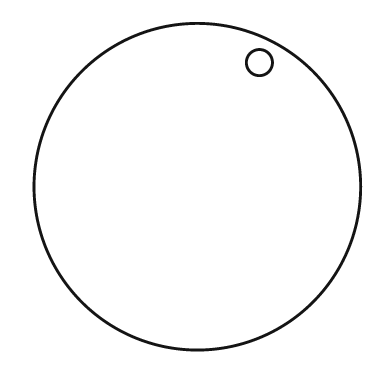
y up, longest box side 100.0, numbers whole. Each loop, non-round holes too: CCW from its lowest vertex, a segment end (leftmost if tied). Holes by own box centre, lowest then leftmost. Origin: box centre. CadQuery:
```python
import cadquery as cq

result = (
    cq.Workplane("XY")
    .moveTo(0.0, 0.0)
    .circle(50.0)
    .moveTo(19.0, 38.0)
    .circle(4.0)
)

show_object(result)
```